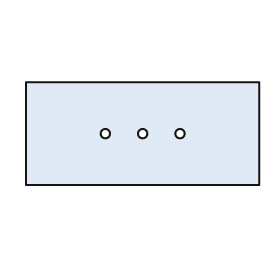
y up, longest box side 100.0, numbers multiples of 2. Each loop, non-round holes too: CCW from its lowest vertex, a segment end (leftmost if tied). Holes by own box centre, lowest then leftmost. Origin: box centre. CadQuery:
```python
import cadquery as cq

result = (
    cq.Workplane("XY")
    .moveTo(-50.0, -22.0)
    .lineTo(50.0, -22.0)
    .lineTo(50.0, 22.0)
    .lineTo(-50.0, 22.0)
    .close()
    .moveTo(-16.0, 0.0)
    .circle(2.0)
    .moveTo(0.0, 0.0)
    .circle(2.0)
    .moveTo(16.0, 0.0)
    .circle(2.0)
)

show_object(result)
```